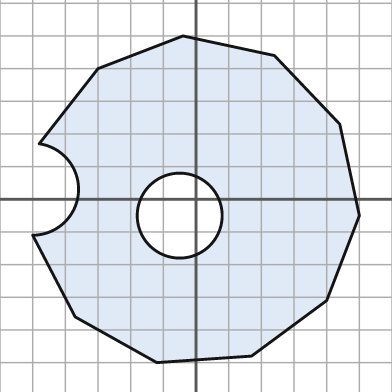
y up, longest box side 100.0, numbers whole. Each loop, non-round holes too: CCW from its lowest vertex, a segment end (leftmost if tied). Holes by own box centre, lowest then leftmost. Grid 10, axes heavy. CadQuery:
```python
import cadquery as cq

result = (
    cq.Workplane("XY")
    .moveTo(-12.0, -50.0)
    .lineTo(17.0, -48.0)
    .lineTo(40.0, -31.0)
    .lineTo(50.0, -5.0)
    .lineTo(44.0, 23.0)
    .lineTo(24.0, 44.0)
    .lineTo(-4.0, 50.0)
    .lineTo(-30.0, 40.0)
    .lineTo(-48.0, 17.0)
    .threePointArc((-36.0, 2.0), (-50.0, -11.0))
    .lineTo(-37.0, -36.0)
    .close()
    .moveTo(-5.0, -5.0)
    .circle(13.0)
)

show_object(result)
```